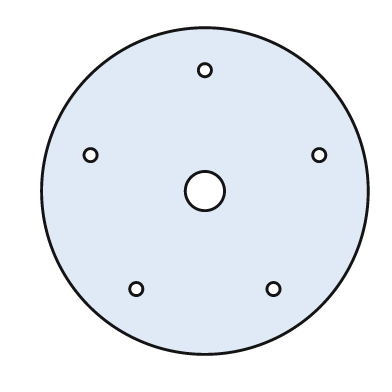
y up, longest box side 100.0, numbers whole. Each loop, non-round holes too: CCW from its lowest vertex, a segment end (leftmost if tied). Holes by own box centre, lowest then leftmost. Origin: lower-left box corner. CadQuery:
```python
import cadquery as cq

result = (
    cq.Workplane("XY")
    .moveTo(50.0, 50.0)
    .circle(50.0)
    .moveTo(29.0, 20.0)
    .circle(2.0)
    .moveTo(71.0, 20.0)
    .circle(2.0)
    .moveTo(50.0, 50.0)
    .circle(6.0)
    .moveTo(15.0, 61.0)
    .circle(2.0)
    .moveTo(85.0, 61.0)
    .circle(2.0)
    .moveTo(50.0, 87.0)
    .circle(2.0)
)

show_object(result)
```